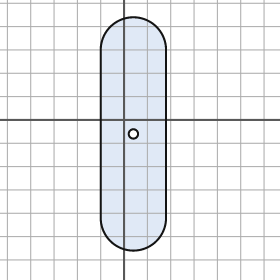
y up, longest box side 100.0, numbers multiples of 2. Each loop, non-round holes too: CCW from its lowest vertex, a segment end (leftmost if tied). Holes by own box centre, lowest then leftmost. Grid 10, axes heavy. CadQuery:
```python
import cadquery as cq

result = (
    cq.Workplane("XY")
    .moveTo(-10.0, -42.0)
    .threePointArc((4.0, -56.0), (18.0, -42.0))
    .lineTo(18.0, 30.0)
    .threePointArc((4.0, 44.0), (-10.0, 30.0))
    .close()
    .moveTo(4.0, -6.0)
    .circle(2.0)
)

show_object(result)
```